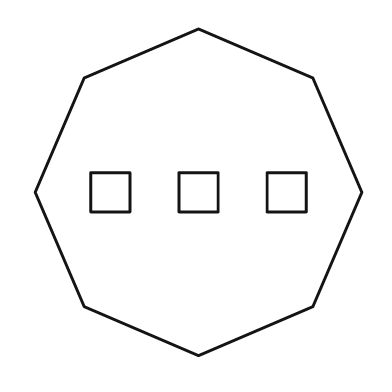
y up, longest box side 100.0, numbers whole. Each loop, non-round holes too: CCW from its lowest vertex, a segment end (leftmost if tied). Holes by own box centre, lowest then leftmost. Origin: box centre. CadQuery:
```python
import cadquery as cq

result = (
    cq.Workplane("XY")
    .moveTo(0.0, -50.0)
    .lineTo(35.0, -35.0)
    .lineTo(50.0, 0.0)
    .lineTo(35.0, 35.0)
    .lineTo(0.0, 50.0)
    .lineTo(-35.0, 35.0)
    .lineTo(-50.0, 0.0)
    .lineTo(-35.0, -35.0)
    .close()
    .moveTo(-33.0, -6.0)
    .lineTo(-21.0, -6.0)
    .lineTo(-21.0, 6.0)
    .lineTo(-33.0, 6.0)
    .close()
    .moveTo(-6.0, -6.0)
    .lineTo(6.0, -6.0)
    .lineTo(6.0, 6.0)
    .lineTo(-6.0, 6.0)
    .close()
    .moveTo(21.0, -6.0)
    .lineTo(33.0, -6.0)
    .lineTo(33.0, 6.0)
    .lineTo(21.0, 6.0)
    .close()
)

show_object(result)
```